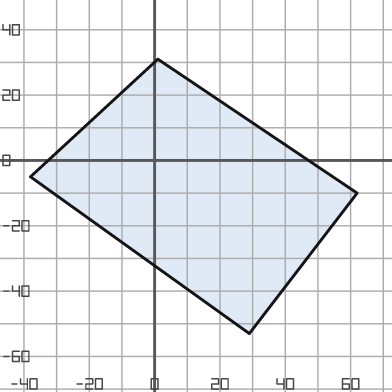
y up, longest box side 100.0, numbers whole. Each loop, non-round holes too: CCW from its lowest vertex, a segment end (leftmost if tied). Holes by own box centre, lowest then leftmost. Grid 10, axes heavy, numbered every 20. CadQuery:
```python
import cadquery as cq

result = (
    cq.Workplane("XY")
    .moveTo(29.0, -53.0)
    .lineTo(62.0, -10.0)
    .lineTo(1.0, 31.0)
    .lineTo(-38.0, -5.0)
    .close()
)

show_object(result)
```